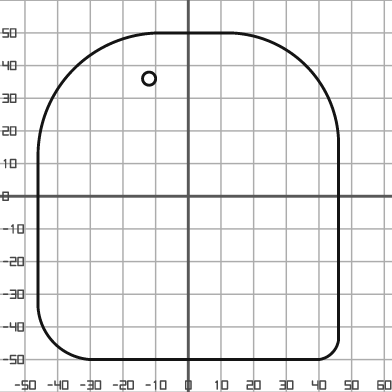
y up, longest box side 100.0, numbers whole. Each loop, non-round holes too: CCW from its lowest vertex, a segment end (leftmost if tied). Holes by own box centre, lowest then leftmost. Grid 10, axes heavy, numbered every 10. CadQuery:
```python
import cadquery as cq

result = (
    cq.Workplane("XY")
    .moveTo(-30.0, -50.0)
    .lineTo(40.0, -50.0)
    .threePointArc((44.0, -48.0), (46.0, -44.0))
    .lineTo(46.0, 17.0)
    .threePointArc((36.0, 40.0), (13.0, 50.0))
    .lineTo(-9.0, 50.0)
    .threePointArc((-35.0, 39.0), (-46.0, 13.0))
    .lineTo(-46.0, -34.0)
    .threePointArc((-41.0, -45.0), (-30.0, -50.0))
    .close()
    .moveTo(-12.0, 36.0)
    .circle(2.0)
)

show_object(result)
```